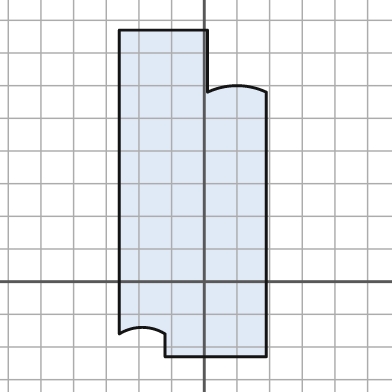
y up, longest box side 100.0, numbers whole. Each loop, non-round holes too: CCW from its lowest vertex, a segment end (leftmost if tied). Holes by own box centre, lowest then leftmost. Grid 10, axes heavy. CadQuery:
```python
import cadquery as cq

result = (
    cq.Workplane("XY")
    .moveTo(-12.0, -23.0)
    .lineTo(19.0, -23.0)
    .lineTo(19.0, 58.0)
    .threePointArc((10.0, 60.0), (1.0, 58.0))
    .lineTo(1.0, 77.0)
    .lineTo(-26.0, 77.0)
    .lineTo(-26.0, -16.0)
    .threePointArc((-19.0, -14.0), (-12.0, -16.0))
    .close()
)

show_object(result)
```